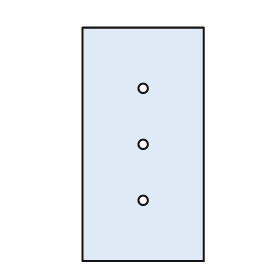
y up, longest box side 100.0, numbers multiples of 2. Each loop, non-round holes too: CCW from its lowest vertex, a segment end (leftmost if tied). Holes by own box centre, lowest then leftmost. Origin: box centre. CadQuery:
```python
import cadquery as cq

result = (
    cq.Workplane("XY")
    .moveTo(-26.0, -50.0)
    .lineTo(26.0, -50.0)
    .lineTo(26.0, 50.0)
    .lineTo(-26.0, 50.0)
    .close()
    .moveTo(0.0, -24.0)
    .circle(2.0)
    .moveTo(0.0, 0.0)
    .circle(2.0)
    .moveTo(0.0, 24.0)
    .circle(2.0)
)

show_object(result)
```